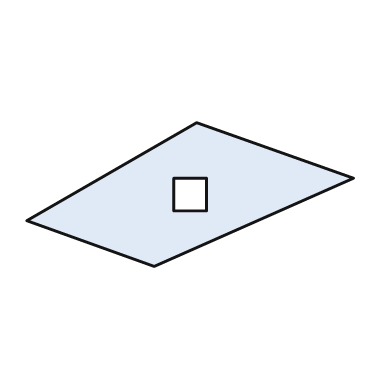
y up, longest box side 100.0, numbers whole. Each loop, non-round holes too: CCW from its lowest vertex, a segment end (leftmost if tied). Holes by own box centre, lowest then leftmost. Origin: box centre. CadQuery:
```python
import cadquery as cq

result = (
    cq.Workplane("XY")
    .moveTo(-11.0, -22.0)
    .lineTo(50.0, 5.0)
    .lineTo(2.0, 22.0)
    .lineTo(-50.0, -8.0)
    .close()
    .moveTo(-5.0, -5.0)
    .lineTo(5.0, -5.0)
    .lineTo(5.0, 5.0)
    .lineTo(-5.0, 5.0)
    .close()
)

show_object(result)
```